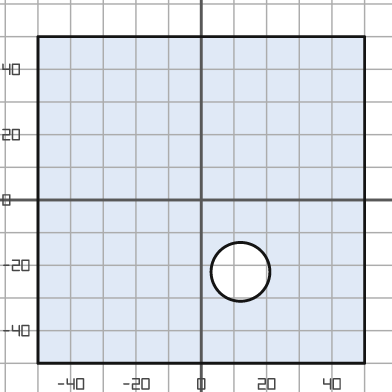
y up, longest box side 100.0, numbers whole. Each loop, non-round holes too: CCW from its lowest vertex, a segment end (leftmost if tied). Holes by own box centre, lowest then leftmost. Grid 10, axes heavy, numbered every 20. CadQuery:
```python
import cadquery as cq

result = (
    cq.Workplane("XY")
    .moveTo(-50.0, -50.0)
    .lineTo(50.0, -50.0)
    .lineTo(50.0, 50.0)
    .lineTo(-50.0, 50.0)
    .close()
    .moveTo(12.0, -22.0)
    .circle(9.0)
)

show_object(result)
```